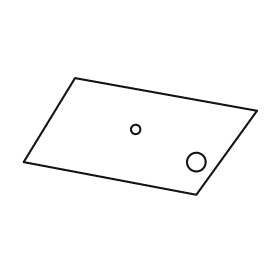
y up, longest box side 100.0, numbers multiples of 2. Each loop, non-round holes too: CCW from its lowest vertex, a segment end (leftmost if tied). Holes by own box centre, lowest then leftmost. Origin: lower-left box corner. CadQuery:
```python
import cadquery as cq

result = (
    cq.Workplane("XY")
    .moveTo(74.0, 0.0)
    .lineTo(100.0, 36.0)
    .lineTo(22.0, 50.0)
    .lineTo(0.0, 14.0)
    .close()
    .moveTo(74.0, 14.0)
    .circle(4.0)
    .moveTo(48.0, 28.0)
    .circle(2.0)
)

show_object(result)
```